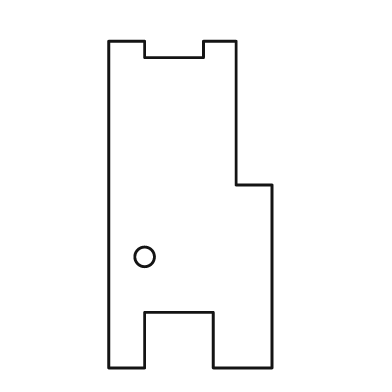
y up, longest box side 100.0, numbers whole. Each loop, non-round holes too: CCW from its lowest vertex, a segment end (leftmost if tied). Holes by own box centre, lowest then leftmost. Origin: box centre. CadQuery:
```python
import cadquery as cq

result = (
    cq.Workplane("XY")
    .moveTo(-25.0, -50.0)
    .lineTo(-14.0, -50.0)
    .lineTo(-14.0, -33.0)
    .lineTo(7.0, -33.0)
    .lineTo(7.0, -50.0)
    .lineTo(25.0, -50.0)
    .lineTo(25.0, 6.0)
    .lineTo(14.0, 6.0)
    .lineTo(14.0, 50.0)
    .lineTo(4.0, 50.0)
    .lineTo(4.0, 45.0)
    .lineTo(-14.0, 45.0)
    .lineTo(-14.0, 50.0)
    .lineTo(-25.0, 50.0)
    .close()
    .moveTo(-14.0, -16.0)
    .circle(3.0)
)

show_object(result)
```